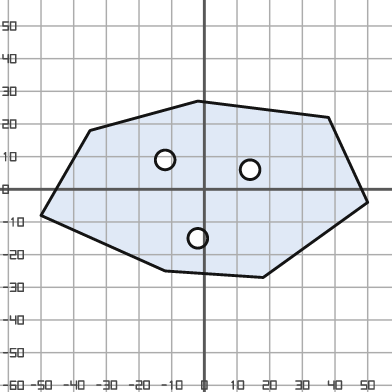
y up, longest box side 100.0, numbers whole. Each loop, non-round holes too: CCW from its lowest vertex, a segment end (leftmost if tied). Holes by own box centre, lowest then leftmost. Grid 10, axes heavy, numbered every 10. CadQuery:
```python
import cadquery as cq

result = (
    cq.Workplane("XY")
    .moveTo(18.0, -27.0)
    .lineTo(50.0, -4.0)
    .lineTo(38.0, 22.0)
    .lineTo(-2.0, 27.0)
    .lineTo(-35.0, 18.0)
    .lineTo(-50.0, -8.0)
    .lineTo(-12.0, -25.0)
    .close()
    .moveTo(-2.0, -15.0)
    .circle(3.0)
    .moveTo(14.0, 6.0)
    .circle(3.0)
    .moveTo(-12.0, 9.0)
    .circle(3.0)
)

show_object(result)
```